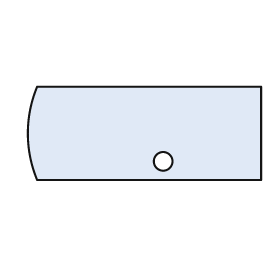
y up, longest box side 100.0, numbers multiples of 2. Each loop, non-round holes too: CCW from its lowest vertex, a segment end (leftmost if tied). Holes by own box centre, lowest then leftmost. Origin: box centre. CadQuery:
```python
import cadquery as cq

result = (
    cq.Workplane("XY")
    .moveTo(-46.0, -20.0)
    .lineTo(50.0, -20.0)
    .lineTo(50.0, 20.0)
    .lineTo(-46.0, 20.0)
    .threePointArc((-50.0, 0.0), (-46.0, -20.0))
    .close()
    .moveTo(8.0, -12.0)
    .circle(4.0)
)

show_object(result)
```